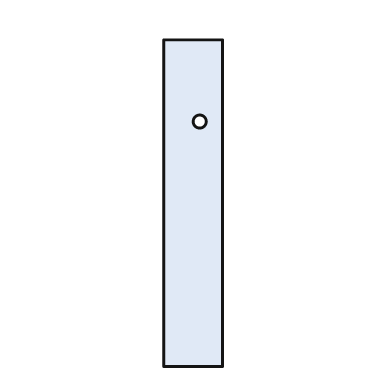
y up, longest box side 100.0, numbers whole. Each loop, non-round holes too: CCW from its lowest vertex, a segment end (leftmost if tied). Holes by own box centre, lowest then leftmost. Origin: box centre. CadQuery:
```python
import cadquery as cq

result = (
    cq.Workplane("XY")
    .moveTo(-9.0, -50.0)
    .lineTo(9.0, -50.0)
    .lineTo(9.0, 50.0)
    .lineTo(-9.0, 50.0)
    .close()
    .moveTo(2.0, 25.0)
    .circle(2.0)
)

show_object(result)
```